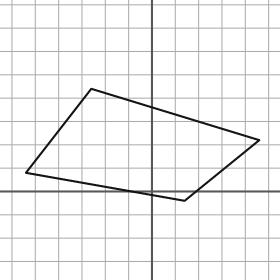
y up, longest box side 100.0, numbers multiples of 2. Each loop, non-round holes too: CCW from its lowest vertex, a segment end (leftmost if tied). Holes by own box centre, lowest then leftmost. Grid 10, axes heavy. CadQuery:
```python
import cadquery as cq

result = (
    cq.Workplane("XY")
    .moveTo(14.0, -4.0)
    .lineTo(46.0, 22.0)
    .lineTo(-26.0, 44.0)
    .lineTo(-54.0, 8.0)
    .close()
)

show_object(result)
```